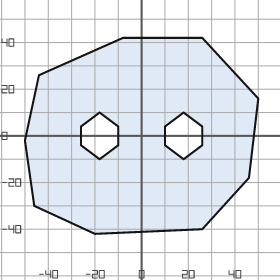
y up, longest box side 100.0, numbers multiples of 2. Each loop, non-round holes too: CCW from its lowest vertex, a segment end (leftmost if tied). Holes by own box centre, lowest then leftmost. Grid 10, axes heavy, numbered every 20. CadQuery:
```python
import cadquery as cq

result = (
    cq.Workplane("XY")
    .moveTo(-20.0, -42.0)
    .lineTo(26.0, -40.0)
    .lineTo(46.0, -18.0)
    .lineTo(50.0, 16.0)
    .lineTo(26.0, 42.0)
    .lineTo(-8.0, 42.0)
    .lineTo(-44.0, 26.0)
    .lineTo(-50.0, -2.0)
    .lineTo(-46.0, -30.0)
    .close()
    .moveTo(-18.0, -10.0)
    .lineTo(-10.0, -4.0)
    .lineTo(-10.0, 4.0)
    .lineTo(-18.0, 10.0)
    .lineTo(-26.0, 4.0)
    .lineTo(-26.0, -4.0)
    .close()
    .moveTo(18.0, -10.0)
    .lineTo(26.0, -4.0)
    .lineTo(26.0, 4.0)
    .lineTo(18.0, 10.0)
    .lineTo(10.0, 4.0)
    .lineTo(10.0, -4.0)
    .close()
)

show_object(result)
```